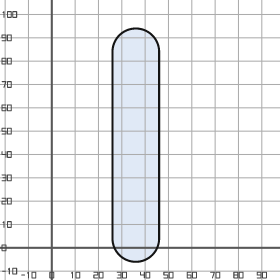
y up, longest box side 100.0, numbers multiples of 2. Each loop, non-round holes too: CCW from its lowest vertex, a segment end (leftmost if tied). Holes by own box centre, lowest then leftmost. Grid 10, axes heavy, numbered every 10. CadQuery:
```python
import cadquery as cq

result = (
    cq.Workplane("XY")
    .moveTo(26.0, 4.0)
    .threePointArc((36.0, -6.0), (46.0, 4.0))
    .lineTo(46.0, 84.0)
    .threePointArc((36.0, 94.0), (26.0, 84.0))
    .close()
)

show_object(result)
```